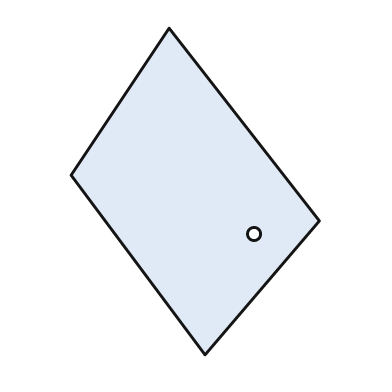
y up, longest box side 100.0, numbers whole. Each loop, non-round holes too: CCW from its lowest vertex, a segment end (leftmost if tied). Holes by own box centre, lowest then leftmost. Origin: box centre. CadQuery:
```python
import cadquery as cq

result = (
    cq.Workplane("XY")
    .moveTo(3.0, -50.0)
    .lineTo(38.0, -9.0)
    .lineTo(-8.0, 50.0)
    .lineTo(-38.0, 5.0)
    .close()
    .moveTo(18.0, -13.0)
    .circle(2.0)
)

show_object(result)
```